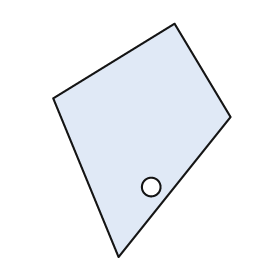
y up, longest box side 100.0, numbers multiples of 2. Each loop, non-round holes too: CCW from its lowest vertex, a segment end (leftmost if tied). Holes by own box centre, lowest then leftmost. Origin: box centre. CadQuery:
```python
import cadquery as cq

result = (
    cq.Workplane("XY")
    .moveTo(-10.0, -50.0)
    .lineTo(38.0, 10.0)
    .lineTo(14.0, 50.0)
    .lineTo(-38.0, 18.0)
    .close()
    .moveTo(4.0, -20.0)
    .circle(4.0)
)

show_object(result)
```